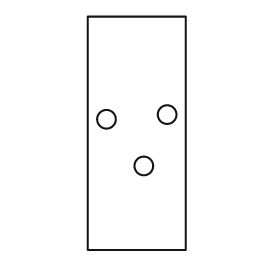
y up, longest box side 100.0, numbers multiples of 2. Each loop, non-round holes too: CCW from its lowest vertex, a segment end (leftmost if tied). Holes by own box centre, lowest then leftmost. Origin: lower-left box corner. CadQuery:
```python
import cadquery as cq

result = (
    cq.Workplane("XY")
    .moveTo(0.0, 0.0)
    .lineTo(42.0, 0.0)
    .lineTo(42.0, 100.0)
    .lineTo(0.0, 100.0)
    .close()
    .moveTo(24.0, 36.0)
    .circle(4.0)
    .moveTo(8.0, 56.0)
    .circle(4.0)
    .moveTo(34.0, 58.0)
    .circle(4.0)
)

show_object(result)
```